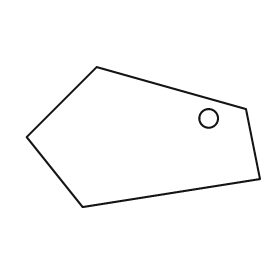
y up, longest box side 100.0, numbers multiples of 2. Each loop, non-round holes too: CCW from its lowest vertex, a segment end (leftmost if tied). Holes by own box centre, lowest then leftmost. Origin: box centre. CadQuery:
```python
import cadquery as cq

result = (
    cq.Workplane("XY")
    .moveTo(-26.0, -30.0)
    .lineTo(50.0, -18.0)
    .lineTo(44.0, 12.0)
    .lineTo(-20.0, 30.0)
    .lineTo(-50.0, 0.0)
    .close()
    .moveTo(28.0, 8.0)
    .circle(4.0)
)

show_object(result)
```